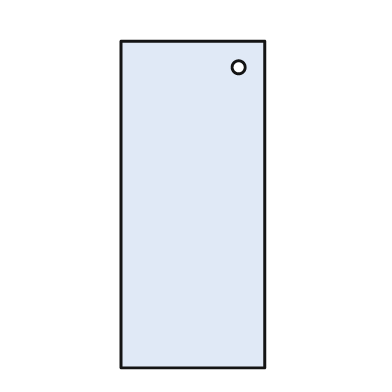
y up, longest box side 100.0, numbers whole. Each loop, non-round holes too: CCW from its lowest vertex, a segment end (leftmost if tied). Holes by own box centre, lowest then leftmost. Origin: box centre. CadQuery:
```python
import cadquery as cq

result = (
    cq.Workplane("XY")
    .moveTo(-22.0, -50.0)
    .lineTo(22.0, -50.0)
    .lineTo(22.0, 50.0)
    .lineTo(-22.0, 50.0)
    .close()
    .moveTo(14.0, 42.0)
    .circle(2.0)
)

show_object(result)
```